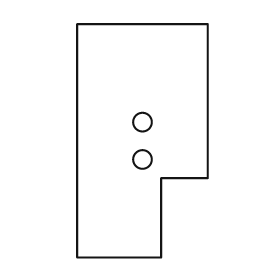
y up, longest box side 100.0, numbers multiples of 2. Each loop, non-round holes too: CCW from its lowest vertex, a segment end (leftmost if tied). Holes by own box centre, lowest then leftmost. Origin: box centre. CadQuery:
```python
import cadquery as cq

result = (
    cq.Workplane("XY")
    .moveTo(-28.0, -50.0)
    .lineTo(8.0, -50.0)
    .lineTo(8.0, -16.0)
    .lineTo(28.0, -16.0)
    .lineTo(28.0, 50.0)
    .lineTo(-28.0, 50.0)
    .close()
    .moveTo(0.0, -8.0)
    .circle(4.0)
    .moveTo(0.0, 8.0)
    .circle(4.0)
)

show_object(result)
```